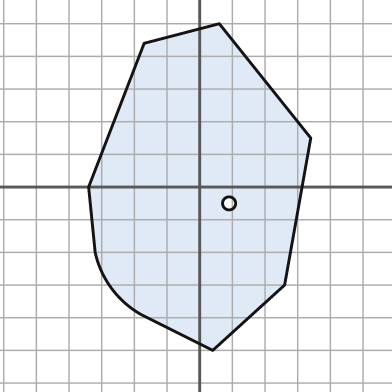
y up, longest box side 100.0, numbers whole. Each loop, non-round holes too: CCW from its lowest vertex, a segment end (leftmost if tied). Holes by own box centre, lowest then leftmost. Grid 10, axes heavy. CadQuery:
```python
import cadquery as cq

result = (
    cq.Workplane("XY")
    .moveTo(4.0, -50.0)
    .lineTo(26.0, -30.0)
    .lineTo(34.0, 15.0)
    .lineTo(6.0, 50.0)
    .lineTo(-17.0, 44.0)
    .lineTo(-34.0, 0.0)
    .lineTo(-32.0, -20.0)
    .threePointArc((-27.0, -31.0), (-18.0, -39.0))
    .close()
    .moveTo(9.0, -5.0)
    .circle(2.0)
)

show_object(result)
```